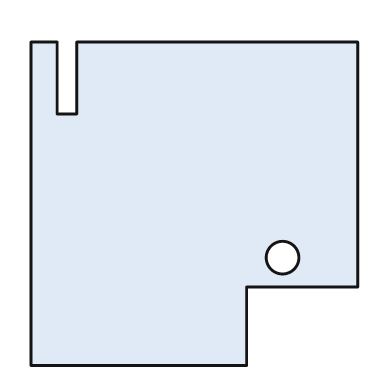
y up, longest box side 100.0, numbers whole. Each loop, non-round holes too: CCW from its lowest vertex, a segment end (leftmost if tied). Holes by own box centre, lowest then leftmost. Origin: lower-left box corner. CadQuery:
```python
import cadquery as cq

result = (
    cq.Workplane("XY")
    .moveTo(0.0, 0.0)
    .lineTo(66.0, 0.0)
    .lineTo(66.0, 24.0)
    .lineTo(100.0, 24.0)
    .lineTo(100.0, 99.0)
    .lineTo(14.0, 99.0)
    .lineTo(14.0, 77.0)
    .lineTo(8.0, 77.0)
    .lineTo(8.0, 99.0)
    .lineTo(0.0, 99.0)
    .close()
    .moveTo(77.0, 33.0)
    .circle(5.0)
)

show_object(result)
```